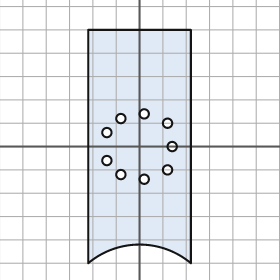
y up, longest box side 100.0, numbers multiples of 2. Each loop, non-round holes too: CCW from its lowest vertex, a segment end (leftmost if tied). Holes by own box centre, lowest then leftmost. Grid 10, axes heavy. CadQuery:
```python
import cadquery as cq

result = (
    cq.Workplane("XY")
    .moveTo(-22.0, -50.0)
    .threePointArc((0.0, -42.0), (22.0, -50.0))
    .lineTo(22.0, 50.0)
    .lineTo(-22.0, 50.0)
    .close()
    .moveTo(2.0, -14.0)
    .circle(2.0)
    .moveTo(-8.0, -12.0)
    .circle(2.0)
    .moveTo(12.0, -10.0)
    .circle(2.0)
    .moveTo(-14.0, -6.0)
    .circle(2.0)
    .moveTo(14.0, 0.0)
    .circle(2.0)
    .moveTo(-14.0, 6.0)
    .circle(2.0)
    .moveTo(12.0, 10.0)
    .circle(2.0)
    .moveTo(-8.0, 12.0)
    .circle(2.0)
    .moveTo(2.0, 14.0)
    .circle(2.0)
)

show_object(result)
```